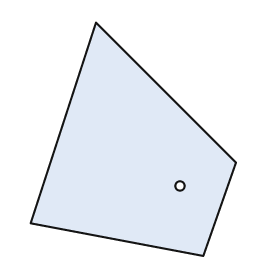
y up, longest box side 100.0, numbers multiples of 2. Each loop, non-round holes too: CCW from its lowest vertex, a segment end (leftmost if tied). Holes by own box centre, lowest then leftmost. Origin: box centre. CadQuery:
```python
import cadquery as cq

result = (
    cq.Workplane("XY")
    .moveTo(30.0, -50.0)
    .lineTo(44.0, -10.0)
    .lineTo(-16.0, 50.0)
    .lineTo(-44.0, -36.0)
    .close()
    .moveTo(20.0, -20.0)
    .circle(2.0)
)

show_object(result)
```